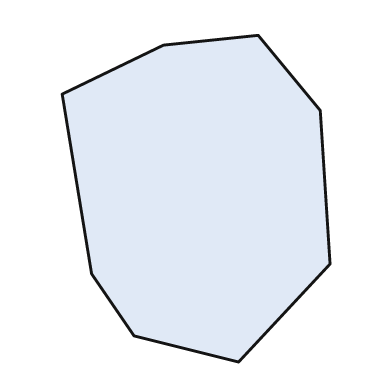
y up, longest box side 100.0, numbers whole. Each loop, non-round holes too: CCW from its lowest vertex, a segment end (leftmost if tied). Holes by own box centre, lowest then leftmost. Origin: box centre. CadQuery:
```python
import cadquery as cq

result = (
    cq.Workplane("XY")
    .moveTo(13.0, -50.0)
    .lineTo(41.0, -20.0)
    .lineTo(38.0, 27.0)
    .lineTo(19.0, 50.0)
    .lineTo(-10.0, 47.0)
    .lineTo(-41.0, 32.0)
    .lineTo(-32.0, -23.0)
    .lineTo(-19.0, -42.0)
    .close()
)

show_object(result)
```